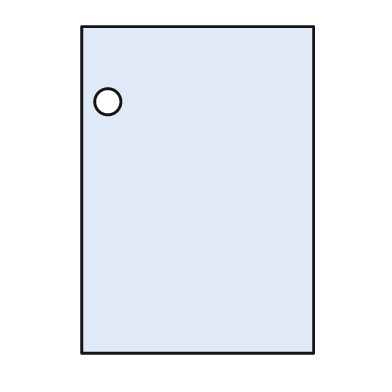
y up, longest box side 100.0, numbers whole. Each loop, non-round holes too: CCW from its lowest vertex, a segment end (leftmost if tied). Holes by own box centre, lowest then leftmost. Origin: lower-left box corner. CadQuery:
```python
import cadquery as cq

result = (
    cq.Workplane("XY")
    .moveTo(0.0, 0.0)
    .lineTo(71.0, 0.0)
    .lineTo(71.0, 100.0)
    .lineTo(0.0, 100.0)
    .close()
    .moveTo(8.0, 77.0)
    .circle(4.0)
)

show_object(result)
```